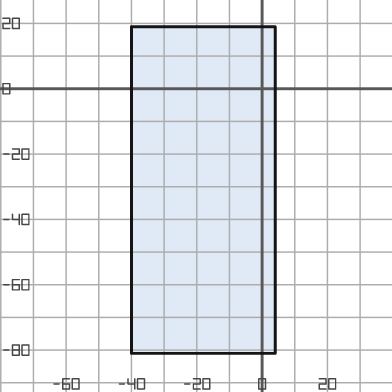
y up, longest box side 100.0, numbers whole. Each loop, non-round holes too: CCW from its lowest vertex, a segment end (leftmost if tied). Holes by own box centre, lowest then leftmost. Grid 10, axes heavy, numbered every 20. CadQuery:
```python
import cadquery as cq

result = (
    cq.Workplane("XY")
    .moveTo(-40.0, -81.0)
    .lineTo(4.0, -81.0)
    .lineTo(4.0, 19.0)
    .lineTo(-40.0, 19.0)
    .close()
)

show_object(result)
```